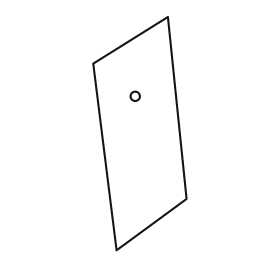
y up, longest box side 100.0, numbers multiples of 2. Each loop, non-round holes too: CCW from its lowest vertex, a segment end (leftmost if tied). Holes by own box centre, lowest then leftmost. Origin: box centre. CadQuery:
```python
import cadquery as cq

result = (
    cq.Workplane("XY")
    .moveTo(-10.0, -50.0)
    .lineTo(20.0, -28.0)
    .lineTo(12.0, 50.0)
    .lineTo(-20.0, 30.0)
    .close()
    .moveTo(-2.0, 16.0)
    .circle(2.0)
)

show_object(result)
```